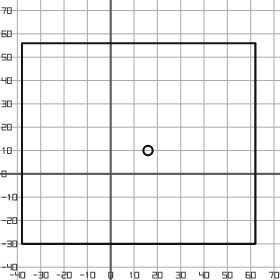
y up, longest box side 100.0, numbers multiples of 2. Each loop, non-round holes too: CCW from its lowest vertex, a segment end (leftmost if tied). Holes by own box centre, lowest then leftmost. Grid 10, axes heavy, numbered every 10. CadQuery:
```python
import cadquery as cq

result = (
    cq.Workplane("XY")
    .moveTo(-38.0, -30.0)
    .lineTo(62.0, -30.0)
    .lineTo(62.0, 56.0)
    .lineTo(-38.0, 56.0)
    .close()
    .moveTo(16.0, 10.0)
    .circle(2.0)
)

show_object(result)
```